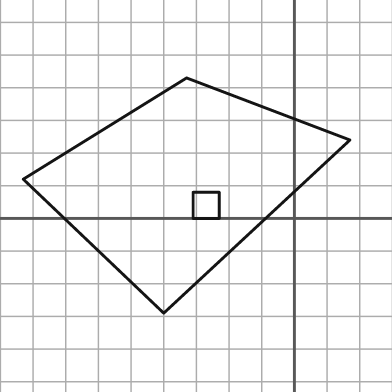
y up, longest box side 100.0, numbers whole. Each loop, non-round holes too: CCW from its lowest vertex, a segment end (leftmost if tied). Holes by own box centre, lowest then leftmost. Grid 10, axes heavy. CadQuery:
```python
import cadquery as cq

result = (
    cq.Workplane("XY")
    .moveTo(-40.0, -29.0)
    .lineTo(17.0, 24.0)
    .lineTo(-33.0, 43.0)
    .lineTo(-83.0, 12.0)
    .close()
    .moveTo(-31.0, 0.0)
    .lineTo(-23.0, 0.0)
    .lineTo(-23.0, 8.0)
    .lineTo(-31.0, 8.0)
    .close()
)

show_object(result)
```